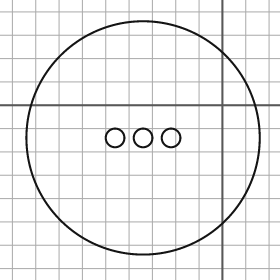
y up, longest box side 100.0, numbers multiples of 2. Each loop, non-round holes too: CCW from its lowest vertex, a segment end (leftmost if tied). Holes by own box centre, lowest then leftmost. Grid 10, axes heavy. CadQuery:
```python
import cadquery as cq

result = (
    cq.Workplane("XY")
    .moveTo(-34.0, -14.0)
    .circle(50.0)
    .moveTo(-46.0, -14.0)
    .circle(4.0)
    .moveTo(-34.0, -14.0)
    .circle(4.0)
    .moveTo(-22.0, -14.0)
    .circle(4.0)
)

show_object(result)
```